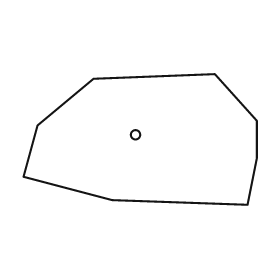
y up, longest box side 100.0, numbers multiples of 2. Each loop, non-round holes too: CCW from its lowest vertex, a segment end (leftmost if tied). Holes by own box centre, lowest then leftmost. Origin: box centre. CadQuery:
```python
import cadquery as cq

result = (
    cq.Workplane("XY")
    .moveTo(46.0, -28.0)
    .lineTo(50.0, -8.0)
    .lineTo(50.0, 8.0)
    .lineTo(32.0, 28.0)
    .lineTo(-20.0, 26.0)
    .lineTo(-44.0, 6.0)
    .lineTo(-50.0, -16.0)
    .lineTo(-12.0, -26.0)
    .close()
    .moveTo(-2.0, 2.0)
    .circle(2.0)
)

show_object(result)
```